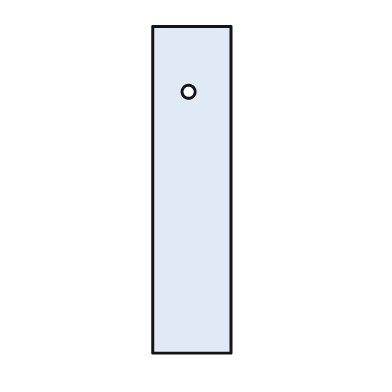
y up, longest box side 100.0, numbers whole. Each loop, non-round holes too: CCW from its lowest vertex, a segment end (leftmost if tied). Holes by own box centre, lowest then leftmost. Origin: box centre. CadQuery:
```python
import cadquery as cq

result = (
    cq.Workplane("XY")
    .moveTo(-12.0, -50.0)
    .lineTo(12.0, -50.0)
    .lineTo(12.0, 50.0)
    .lineTo(-12.0, 50.0)
    .close()
    .moveTo(-1.0, 30.0)
    .circle(2.0)
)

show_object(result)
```